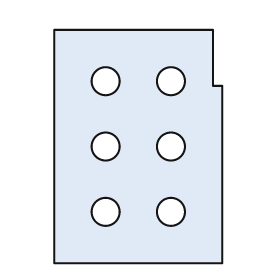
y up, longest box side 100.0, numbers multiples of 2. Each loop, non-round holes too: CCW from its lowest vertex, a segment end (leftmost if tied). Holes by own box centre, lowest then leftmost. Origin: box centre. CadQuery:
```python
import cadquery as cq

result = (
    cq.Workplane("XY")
    .moveTo(-36.0, -50.0)
    .lineTo(36.0, -50.0)
    .lineTo(36.0, 26.0)
    .lineTo(32.0, 26.0)
    .lineTo(32.0, 50.0)
    .lineTo(-36.0, 50.0)
    .close()
    .moveTo(-14.0, -28.0)
    .circle(6.0)
    .moveTo(14.0, -28.0)
    .circle(6.0)
    .moveTo(-14.0, 0.0)
    .circle(6.0)
    .moveTo(14.0, 0.0)
    .circle(6.0)
    .moveTo(-14.0, 28.0)
    .circle(6.0)
    .moveTo(14.0, 28.0)
    .circle(6.0)
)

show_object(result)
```